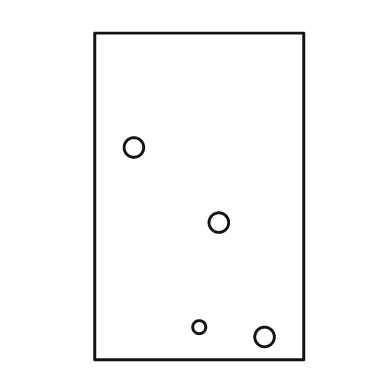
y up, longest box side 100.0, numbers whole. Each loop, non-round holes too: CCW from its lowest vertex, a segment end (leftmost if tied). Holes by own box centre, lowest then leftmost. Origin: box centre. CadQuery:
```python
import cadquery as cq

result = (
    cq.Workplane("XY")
    .moveTo(-32.0, -50.0)
    .lineTo(32.0, -50.0)
    .lineTo(32.0, 50.0)
    .lineTo(-32.0, 50.0)
    .close()
    .moveTo(20.0, -43.0)
    .circle(3.0)
    .moveTo(0.0, -40.0)
    .circle(2.0)
    .moveTo(6.0, -8.0)
    .circle(3.0)
    .moveTo(-20.0, 15.0)
    .circle(3.0)
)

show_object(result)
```